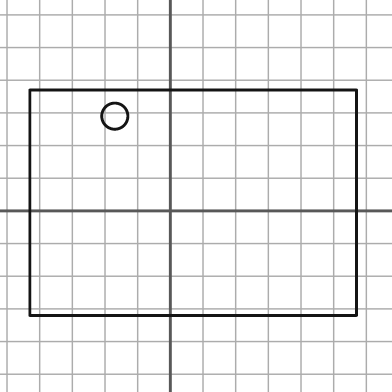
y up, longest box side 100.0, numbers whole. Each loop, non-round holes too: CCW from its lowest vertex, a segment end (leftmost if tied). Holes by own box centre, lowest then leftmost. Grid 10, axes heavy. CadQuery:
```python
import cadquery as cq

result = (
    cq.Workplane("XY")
    .moveTo(-43.0, -32.0)
    .lineTo(57.0, -32.0)
    .lineTo(57.0, 37.0)
    .lineTo(-43.0, 37.0)
    .close()
    .moveTo(-17.0, 29.0)
    .circle(4.0)
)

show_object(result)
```